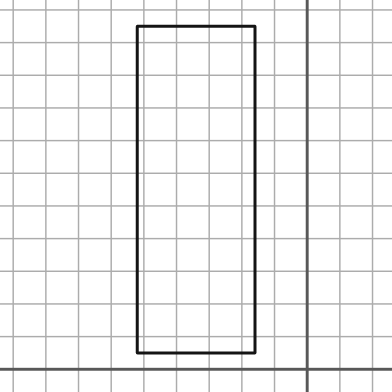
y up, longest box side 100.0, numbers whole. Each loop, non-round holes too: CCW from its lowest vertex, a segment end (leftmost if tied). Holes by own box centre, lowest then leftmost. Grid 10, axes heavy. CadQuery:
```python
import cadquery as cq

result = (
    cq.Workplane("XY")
    .moveTo(-52.0, 5.0)
    .lineTo(-16.0, 5.0)
    .lineTo(-16.0, 105.0)
    .lineTo(-52.0, 105.0)
    .close()
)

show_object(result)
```